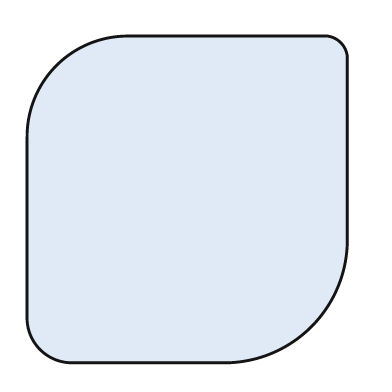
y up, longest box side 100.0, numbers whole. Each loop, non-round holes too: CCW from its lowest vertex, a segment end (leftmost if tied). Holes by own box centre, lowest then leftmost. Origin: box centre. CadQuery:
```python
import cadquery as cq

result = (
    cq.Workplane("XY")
    .moveTo(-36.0, -50.0)
    .lineTo(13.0, -50.0)
    .threePointArc((38.0, -39.0), (49.0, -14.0))
    .lineTo(49.0, 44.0)
    .threePointArc((47.0, 48.0), (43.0, 50.0))
    .lineTo(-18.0, 50.0)
    .threePointArc((-40.0, 41.0), (-49.0, 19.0))
    .lineTo(-49.0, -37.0)
    .threePointArc((-45.0, -46.0), (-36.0, -50.0))
    .close()
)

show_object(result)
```